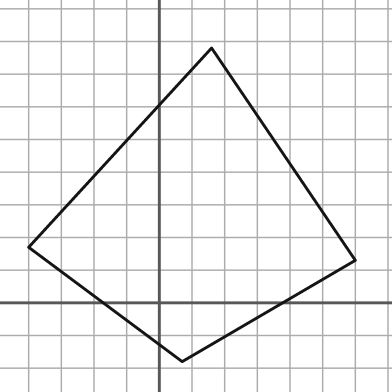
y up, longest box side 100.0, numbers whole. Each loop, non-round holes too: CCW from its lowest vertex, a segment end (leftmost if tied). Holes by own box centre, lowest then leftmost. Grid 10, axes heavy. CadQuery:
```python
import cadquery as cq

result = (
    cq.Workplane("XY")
    .moveTo(7.0, -18.0)
    .lineTo(60.0, 13.0)
    .lineTo(16.0, 78.0)
    .lineTo(-40.0, 17.0)
    .close()
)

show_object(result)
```